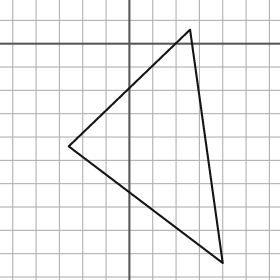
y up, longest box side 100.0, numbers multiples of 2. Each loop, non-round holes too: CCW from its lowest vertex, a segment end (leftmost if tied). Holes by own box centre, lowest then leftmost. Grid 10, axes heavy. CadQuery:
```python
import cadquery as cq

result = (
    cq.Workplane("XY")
    .moveTo(40.0, -94.0)
    .lineTo(26.0, 6.0)
    .lineTo(-26.0, -44.0)
    .close()
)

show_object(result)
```